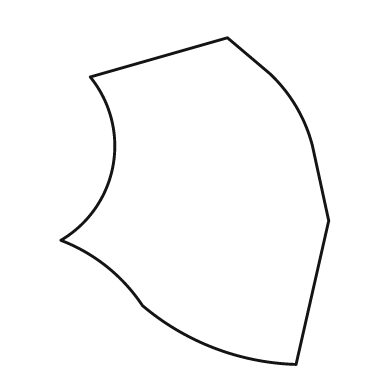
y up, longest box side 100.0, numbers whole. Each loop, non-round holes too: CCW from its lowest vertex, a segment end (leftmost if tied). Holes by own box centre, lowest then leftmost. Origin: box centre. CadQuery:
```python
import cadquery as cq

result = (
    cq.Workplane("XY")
    .moveTo(31.0, -50.0)
    .lineTo(41.0, -6.0)
    .lineTo(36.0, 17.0)
    .threePointArc((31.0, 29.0), (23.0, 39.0))
    .lineTo(10.0, 50.0)
    .lineTo(-32.0, 38.0)
    .threePointArc((-25.0, 11.0), (-41.0, -12.0))
    .threePointArc((-27.0, -20.0), (-16.0, -32.0))
    .threePointArc((6.0, -45.0), (31.0, -50.0))
    .close()
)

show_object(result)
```